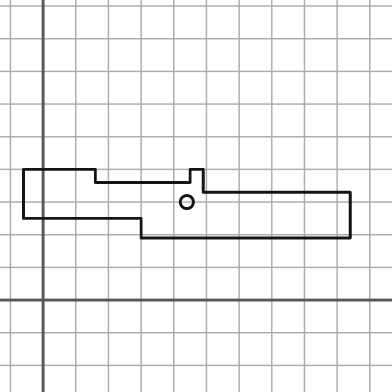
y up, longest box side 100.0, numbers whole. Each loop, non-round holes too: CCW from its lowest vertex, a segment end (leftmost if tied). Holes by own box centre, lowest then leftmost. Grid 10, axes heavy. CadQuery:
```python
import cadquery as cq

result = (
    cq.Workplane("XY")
    .moveTo(30.0, 19.0)
    .lineTo(94.0, 19.0)
    .lineTo(94.0, 33.0)
    .lineTo(49.0, 33.0)
    .lineTo(49.0, 40.0)
    .lineTo(45.0, 40.0)
    .lineTo(45.0, 36.0)
    .lineTo(16.0, 36.0)
    .lineTo(16.0, 40.0)
    .lineTo(-6.0, 40.0)
    .lineTo(-6.0, 25.0)
    .lineTo(30.0, 25.0)
    .close()
    .moveTo(44.0, 30.0)
    .circle(2.0)
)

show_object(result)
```